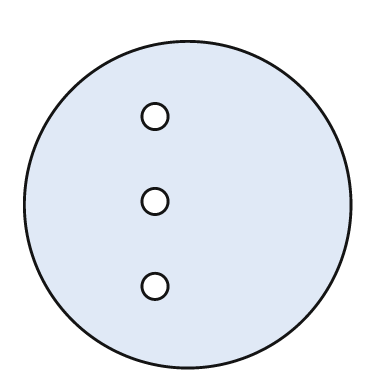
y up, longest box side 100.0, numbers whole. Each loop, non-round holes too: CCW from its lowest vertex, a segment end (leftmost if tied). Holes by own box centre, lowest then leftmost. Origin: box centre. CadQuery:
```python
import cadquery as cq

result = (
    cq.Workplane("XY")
    .moveTo(0.0, 0.0)
    .circle(50.0)
    .moveTo(-10.0, -25.0)
    .circle(4.0)
    .moveTo(-10.0, 1.0)
    .circle(4.0)
    .moveTo(-10.0, 27.0)
    .circle(4.0)
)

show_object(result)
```